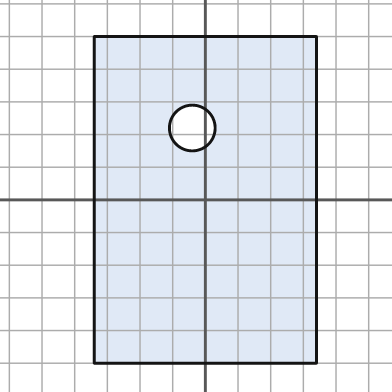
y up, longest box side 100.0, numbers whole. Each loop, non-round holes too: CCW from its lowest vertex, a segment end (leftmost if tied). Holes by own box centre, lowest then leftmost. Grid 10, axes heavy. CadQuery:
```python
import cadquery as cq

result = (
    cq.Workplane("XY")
    .moveTo(-34.0, -50.0)
    .lineTo(34.0, -50.0)
    .lineTo(34.0, 50.0)
    .lineTo(-34.0, 50.0)
    .close()
    .moveTo(-4.0, 22.0)
    .circle(7.0)
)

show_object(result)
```